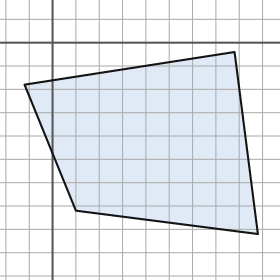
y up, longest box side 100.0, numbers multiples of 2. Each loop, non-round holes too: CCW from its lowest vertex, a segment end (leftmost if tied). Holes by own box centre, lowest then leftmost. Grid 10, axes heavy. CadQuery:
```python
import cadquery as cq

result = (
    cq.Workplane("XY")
    .moveTo(88.0, -82.0)
    .lineTo(78.0, -4.0)
    .lineTo(-12.0, -18.0)
    .lineTo(10.0, -72.0)
    .close()
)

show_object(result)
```